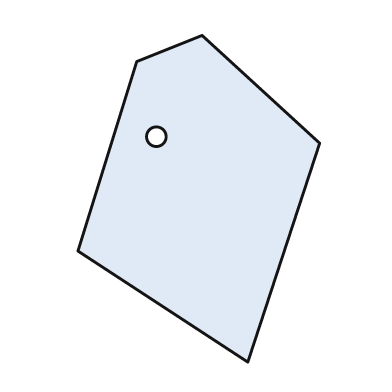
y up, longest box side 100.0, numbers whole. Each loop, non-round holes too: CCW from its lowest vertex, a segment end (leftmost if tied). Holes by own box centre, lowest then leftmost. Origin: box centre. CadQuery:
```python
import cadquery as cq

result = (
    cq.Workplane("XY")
    .moveTo(15.0, -50.0)
    .lineTo(37.0, 17.0)
    .lineTo(1.0, 50.0)
    .lineTo(-19.0, 42.0)
    .lineTo(-37.0, -16.0)
    .close()
    .moveTo(-13.0, 19.0)
    .circle(3.0)
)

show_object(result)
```